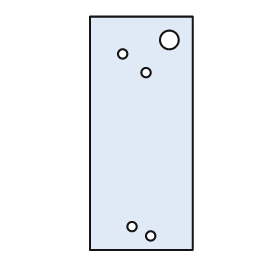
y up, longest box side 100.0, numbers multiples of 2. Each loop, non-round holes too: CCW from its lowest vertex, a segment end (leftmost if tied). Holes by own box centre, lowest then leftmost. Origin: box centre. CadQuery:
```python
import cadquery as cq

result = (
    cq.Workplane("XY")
    .moveTo(-22.0, -50.0)
    .lineTo(22.0, -50.0)
    .lineTo(22.0, 50.0)
    .lineTo(-22.0, 50.0)
    .close()
    .moveTo(4.0, -44.0)
    .circle(2.0)
    .moveTo(-4.0, -40.0)
    .circle(2.0)
    .moveTo(2.0, 26.0)
    .circle(2.0)
    .moveTo(-8.0, 34.0)
    .circle(2.0)
    .moveTo(12.0, 40.0)
    .circle(4.0)
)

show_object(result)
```